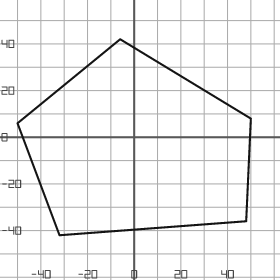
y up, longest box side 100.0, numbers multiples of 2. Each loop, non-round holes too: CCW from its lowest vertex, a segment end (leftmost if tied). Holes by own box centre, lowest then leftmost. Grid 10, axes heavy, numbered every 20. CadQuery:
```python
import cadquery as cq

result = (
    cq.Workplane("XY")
    .moveTo(-32.0, -42.0)
    .lineTo(48.0, -36.0)
    .lineTo(50.0, 8.0)
    .lineTo(-6.0, 42.0)
    .lineTo(-50.0, 6.0)
    .close()
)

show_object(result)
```